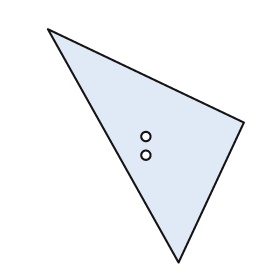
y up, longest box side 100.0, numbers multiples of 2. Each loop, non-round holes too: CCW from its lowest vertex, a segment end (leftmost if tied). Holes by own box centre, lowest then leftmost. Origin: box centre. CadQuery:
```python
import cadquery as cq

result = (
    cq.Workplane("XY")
    .moveTo(14.0, -50.0)
    .lineTo(42.0, 10.0)
    .lineTo(-42.0, 50.0)
    .close()
    .moveTo(0.0, -4.0)
    .circle(2.0)
    .moveTo(0.0, 4.0)
    .circle(2.0)
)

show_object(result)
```